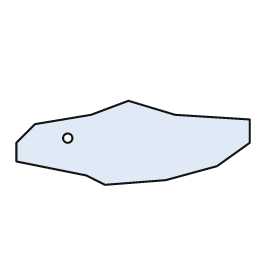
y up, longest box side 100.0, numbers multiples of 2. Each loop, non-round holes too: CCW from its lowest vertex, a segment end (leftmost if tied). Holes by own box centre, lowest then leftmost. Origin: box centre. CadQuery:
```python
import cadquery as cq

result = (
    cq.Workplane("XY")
    .moveTo(-12.0, -18.0)
    .lineTo(14.0, -16.0)
    .lineTo(36.0, -10.0)
    .lineTo(50.0, 0.0)
    .lineTo(50.0, 10.0)
    .lineTo(18.0, 12.0)
    .lineTo(-2.0, 18.0)
    .lineTo(-18.0, 12.0)
    .lineTo(-42.0, 8.0)
    .lineTo(-50.0, 0.0)
    .lineTo(-50.0, -8.0)
    .lineTo(-20.0, -14.0)
    .close()
    .moveTo(-28.0, 2.0)
    .circle(2.0)
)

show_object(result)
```